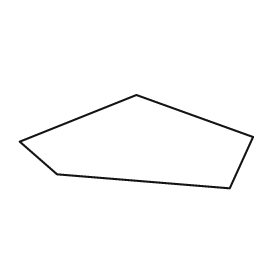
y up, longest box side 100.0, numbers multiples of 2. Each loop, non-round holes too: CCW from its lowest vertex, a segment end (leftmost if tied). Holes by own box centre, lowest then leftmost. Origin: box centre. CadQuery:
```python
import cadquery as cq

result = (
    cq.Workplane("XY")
    .moveTo(40.0, -20.0)
    .lineTo(50.0, 2.0)
    .lineTo(0.0, 20.0)
    .lineTo(-50.0, 0.0)
    .lineTo(-34.0, -14.0)
    .close()
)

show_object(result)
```